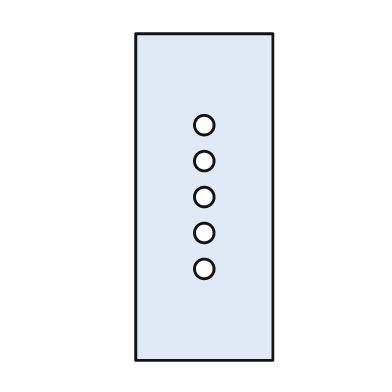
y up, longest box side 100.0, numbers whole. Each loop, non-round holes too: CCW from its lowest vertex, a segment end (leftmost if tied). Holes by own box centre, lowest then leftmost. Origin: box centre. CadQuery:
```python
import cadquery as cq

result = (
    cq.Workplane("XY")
    .moveTo(-21.0, -50.0)
    .lineTo(21.0, -50.0)
    .lineTo(21.0, 50.0)
    .lineTo(-21.0, 50.0)
    .close()
    .moveTo(0.0, -22.0)
    .circle(3.0)
    .moveTo(0.0, -11.0)
    .circle(3.0)
    .moveTo(0.0, 0.0)
    .circle(3.0)
    .moveTo(0.0, 11.0)
    .circle(3.0)
    .moveTo(0.0, 22.0)
    .circle(3.0)
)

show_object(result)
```